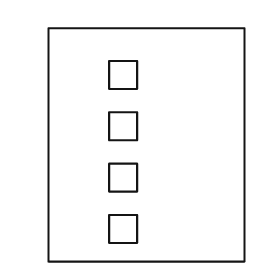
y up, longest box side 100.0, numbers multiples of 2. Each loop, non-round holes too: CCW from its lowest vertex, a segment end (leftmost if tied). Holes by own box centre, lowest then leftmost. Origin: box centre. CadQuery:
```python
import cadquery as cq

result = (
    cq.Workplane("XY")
    .moveTo(-42.0, -50.0)
    .lineTo(42.0, -50.0)
    .lineTo(42.0, 50.0)
    .lineTo(-42.0, 50.0)
    .close()
    .moveTo(-16.0, -42.0)
    .lineTo(-4.0, -42.0)
    .lineTo(-4.0, -30.0)
    .lineTo(-16.0, -30.0)
    .close()
    .moveTo(-16.0, -20.0)
    .lineTo(-4.0, -20.0)
    .lineTo(-4.0, -8.0)
    .lineTo(-16.0, -8.0)
    .close()
    .moveTo(-16.0, 2.0)
    .lineTo(-4.0, 2.0)
    .lineTo(-4.0, 14.0)
    .lineTo(-16.0, 14.0)
    .close()
    .moveTo(-16.0, 24.0)
    .lineTo(-4.0, 24.0)
    .lineTo(-4.0, 36.0)
    .lineTo(-16.0, 36.0)
    .close()
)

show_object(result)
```